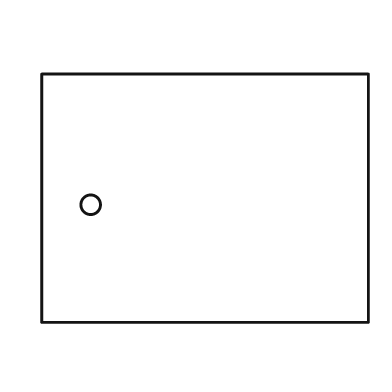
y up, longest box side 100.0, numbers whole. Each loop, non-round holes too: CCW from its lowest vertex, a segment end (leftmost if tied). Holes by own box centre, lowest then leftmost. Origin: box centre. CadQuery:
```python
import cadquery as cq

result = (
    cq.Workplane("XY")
    .moveTo(-50.0, -38.0)
    .lineTo(50.0, -38.0)
    .lineTo(50.0, 38.0)
    .lineTo(-50.0, 38.0)
    .close()
    .moveTo(-35.0, -2.0)
    .circle(3.0)
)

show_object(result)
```